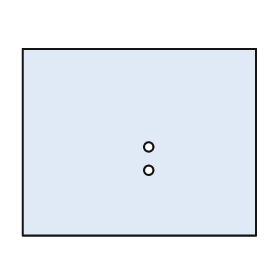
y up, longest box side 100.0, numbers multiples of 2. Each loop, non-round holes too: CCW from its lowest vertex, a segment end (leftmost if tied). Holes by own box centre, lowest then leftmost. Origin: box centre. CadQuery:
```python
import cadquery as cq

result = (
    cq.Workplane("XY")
    .moveTo(-50.0, -40.0)
    .lineTo(50.0, -40.0)
    .lineTo(50.0, 40.0)
    .lineTo(-50.0, 40.0)
    .close()
    .moveTo(4.0, -12.0)
    .circle(2.0)
    .moveTo(4.0, -2.0)
    .circle(2.0)
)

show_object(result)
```